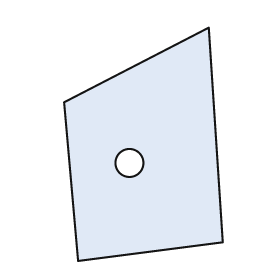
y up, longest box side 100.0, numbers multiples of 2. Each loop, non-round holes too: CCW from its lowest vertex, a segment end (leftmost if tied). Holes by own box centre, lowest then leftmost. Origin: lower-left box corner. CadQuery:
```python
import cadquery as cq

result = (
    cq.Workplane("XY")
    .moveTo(6.0, 0.0)
    .lineTo(68.0, 8.0)
    .lineTo(62.0, 100.0)
    .lineTo(0.0, 68.0)
    .close()
    .moveTo(28.0, 42.0)
    .circle(6.0)
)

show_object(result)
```